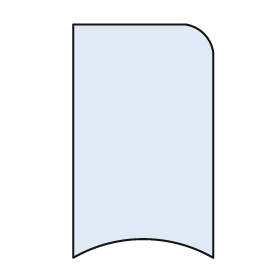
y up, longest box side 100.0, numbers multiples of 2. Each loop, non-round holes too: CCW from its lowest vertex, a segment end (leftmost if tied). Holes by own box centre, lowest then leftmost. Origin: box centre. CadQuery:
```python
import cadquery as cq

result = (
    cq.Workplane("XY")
    .moveTo(-30.0, -50.0)
    .threePointArc((0.0, -42.0), (30.0, -50.0))
    .lineTo(30.0, 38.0)
    .threePointArc((26.0, 46.0), (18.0, 50.0))
    .lineTo(-30.0, 50.0)
    .close()
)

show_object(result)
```